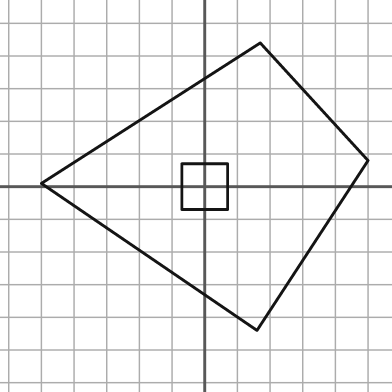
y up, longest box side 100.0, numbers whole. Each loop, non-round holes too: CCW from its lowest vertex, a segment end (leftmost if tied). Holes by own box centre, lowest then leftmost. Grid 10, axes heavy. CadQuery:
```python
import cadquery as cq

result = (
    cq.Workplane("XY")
    .moveTo(16.0, -44.0)
    .lineTo(50.0, 8.0)
    .lineTo(17.0, 44.0)
    .lineTo(-50.0, 1.0)
    .close()
    .moveTo(-7.0, -7.0)
    .lineTo(7.0, -7.0)
    .lineTo(7.0, 7.0)
    .lineTo(-7.0, 7.0)
    .close()
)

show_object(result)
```